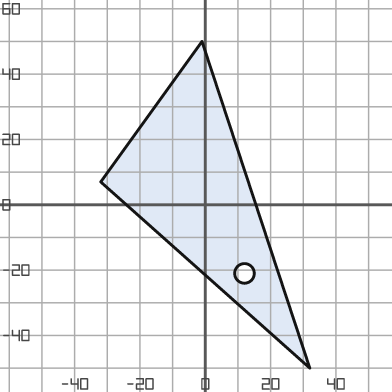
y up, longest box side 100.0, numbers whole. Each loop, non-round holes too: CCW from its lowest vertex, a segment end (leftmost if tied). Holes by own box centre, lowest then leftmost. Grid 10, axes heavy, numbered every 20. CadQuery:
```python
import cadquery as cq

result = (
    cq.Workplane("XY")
    .moveTo(32.0, -50.0)
    .lineTo(-1.0, 50.0)
    .lineTo(-32.0, 7.0)
    .close()
    .moveTo(12.0, -21.0)
    .circle(3.0)
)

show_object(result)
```